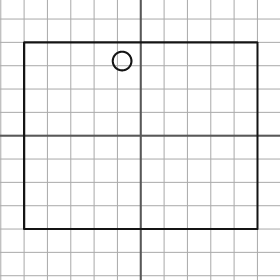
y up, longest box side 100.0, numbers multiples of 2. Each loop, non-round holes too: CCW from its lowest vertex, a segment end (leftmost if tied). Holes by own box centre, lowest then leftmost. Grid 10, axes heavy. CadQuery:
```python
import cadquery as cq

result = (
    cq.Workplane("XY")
    .moveTo(-50.0, -40.0)
    .lineTo(50.0, -40.0)
    .lineTo(50.0, 40.0)
    .lineTo(-50.0, 40.0)
    .close()
    .moveTo(-8.0, 32.0)
    .circle(4.0)
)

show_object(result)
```